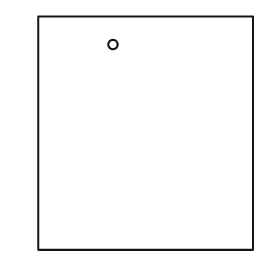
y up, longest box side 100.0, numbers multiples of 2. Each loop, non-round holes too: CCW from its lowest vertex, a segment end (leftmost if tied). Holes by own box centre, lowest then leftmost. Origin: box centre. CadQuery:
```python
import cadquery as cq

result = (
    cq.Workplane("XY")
    .moveTo(-46.0, -50.0)
    .lineTo(46.0, -50.0)
    .lineTo(46.0, 50.0)
    .lineTo(-46.0, 50.0)
    .close()
    .moveTo(-14.0, 38.0)
    .circle(2.0)
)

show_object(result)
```